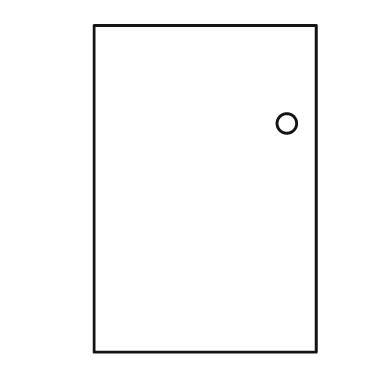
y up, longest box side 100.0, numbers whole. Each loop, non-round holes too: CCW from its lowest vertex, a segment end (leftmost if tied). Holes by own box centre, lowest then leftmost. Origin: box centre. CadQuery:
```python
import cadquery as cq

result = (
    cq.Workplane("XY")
    .moveTo(-34.0, -50.0)
    .lineTo(34.0, -50.0)
    .lineTo(34.0, 50.0)
    .lineTo(-34.0, 50.0)
    .close()
    .moveTo(25.0, 20.0)
    .circle(3.0)
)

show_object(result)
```